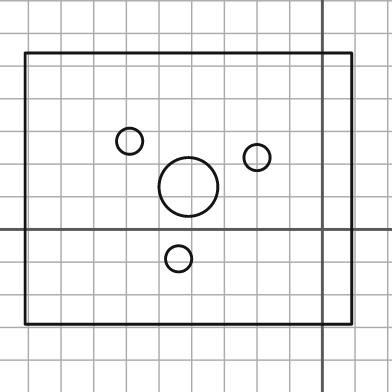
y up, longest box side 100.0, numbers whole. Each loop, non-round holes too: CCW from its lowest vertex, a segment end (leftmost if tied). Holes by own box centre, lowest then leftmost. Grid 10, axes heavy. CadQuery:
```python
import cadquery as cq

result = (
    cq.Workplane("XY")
    .moveTo(-91.0, -29.0)
    .lineTo(9.0, -29.0)
    .lineTo(9.0, 54.0)
    .lineTo(-91.0, 54.0)
    .close()
    .moveTo(-44.0, -9.0)
    .circle(4.0)
    .moveTo(-41.0, 13.0)
    .circle(9.0)
    .moveTo(-20.0, 22.0)
    .circle(4.0)
    .moveTo(-59.0, 27.0)
    .circle(4.0)
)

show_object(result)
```